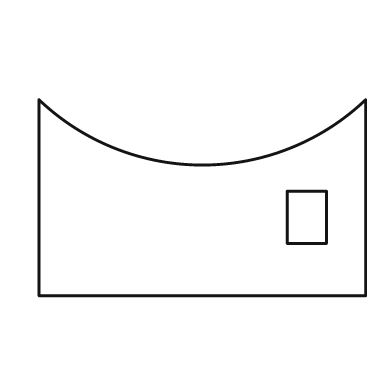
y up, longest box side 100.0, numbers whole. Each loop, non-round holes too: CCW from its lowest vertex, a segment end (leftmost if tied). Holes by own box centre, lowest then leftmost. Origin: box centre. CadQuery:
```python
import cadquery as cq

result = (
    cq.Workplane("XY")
    .moveTo(-50.0, -30.0)
    .lineTo(50.0, -30.0)
    .lineTo(50.0, 30.0)
    .threePointArc((0.0, 10.0), (-50.0, 30.0))
    .close()
    .moveTo(26.0, -14.0)
    .lineTo(38.0, -14.0)
    .lineTo(38.0, 2.0)
    .lineTo(26.0, 2.0)
    .close()
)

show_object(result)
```